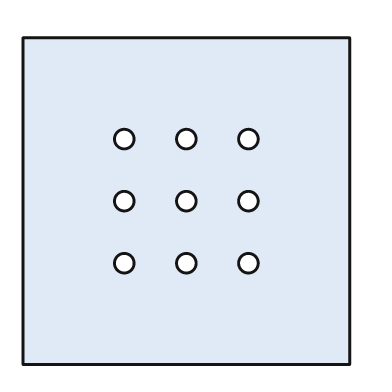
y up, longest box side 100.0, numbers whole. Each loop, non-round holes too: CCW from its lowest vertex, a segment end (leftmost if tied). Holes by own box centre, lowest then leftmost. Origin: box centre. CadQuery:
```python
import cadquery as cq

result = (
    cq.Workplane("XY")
    .moveTo(-50.0, -50.0)
    .lineTo(50.0, -50.0)
    .lineTo(50.0, 50.0)
    .lineTo(-50.0, 50.0)
    .close()
    .moveTo(-19.0, -19.0)
    .circle(3.0)
    .moveTo(0.0, -19.0)
    .circle(3.0)
    .moveTo(19.0, -19.0)
    .circle(3.0)
    .moveTo(-19.0, 0.0)
    .circle(3.0)
    .moveTo(0.0, 0.0)
    .circle(3.0)
    .moveTo(19.0, 0.0)
    .circle(3.0)
    .moveTo(-19.0, 19.0)
    .circle(3.0)
    .moveTo(0.0, 19.0)
    .circle(3.0)
    .moveTo(19.0, 19.0)
    .circle(3.0)
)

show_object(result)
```